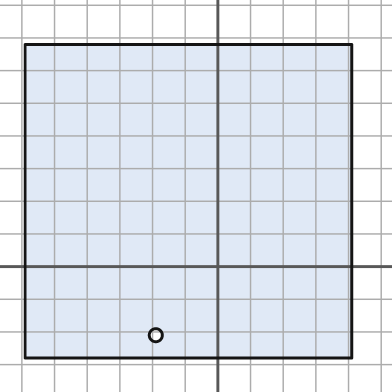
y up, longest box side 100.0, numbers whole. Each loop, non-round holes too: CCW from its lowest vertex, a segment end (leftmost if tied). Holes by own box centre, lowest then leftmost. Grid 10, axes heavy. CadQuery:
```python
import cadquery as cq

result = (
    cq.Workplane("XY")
    .moveTo(-59.0, -28.0)
    .lineTo(41.0, -28.0)
    .lineTo(41.0, 68.0)
    .lineTo(-59.0, 68.0)
    .close()
    .moveTo(-19.0, -21.0)
    .circle(2.0)
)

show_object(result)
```